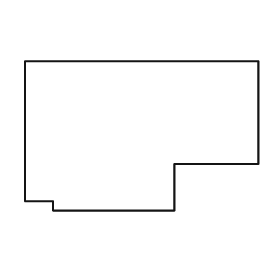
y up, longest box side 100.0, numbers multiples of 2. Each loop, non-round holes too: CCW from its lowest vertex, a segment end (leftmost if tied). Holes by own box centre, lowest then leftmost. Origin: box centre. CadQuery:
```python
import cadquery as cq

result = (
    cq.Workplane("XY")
    .moveTo(-38.0, -32.0)
    .lineTo(14.0, -32.0)
    .lineTo(14.0, -12.0)
    .lineTo(50.0, -12.0)
    .lineTo(50.0, 32.0)
    .lineTo(-50.0, 32.0)
    .lineTo(-50.0, -28.0)
    .lineTo(-38.0, -28.0)
    .close()
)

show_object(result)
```